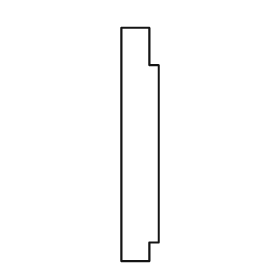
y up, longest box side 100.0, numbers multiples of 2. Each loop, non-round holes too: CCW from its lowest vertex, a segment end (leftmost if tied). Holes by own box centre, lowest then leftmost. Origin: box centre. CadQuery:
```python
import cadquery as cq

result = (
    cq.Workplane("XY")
    .moveTo(-8.0, -50.0)
    .lineTo(4.0, -50.0)
    .lineTo(4.0, -42.0)
    .lineTo(8.0, -42.0)
    .lineTo(8.0, 34.0)
    .lineTo(4.0, 34.0)
    .lineTo(4.0, 50.0)
    .lineTo(-8.0, 50.0)
    .close()
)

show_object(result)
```